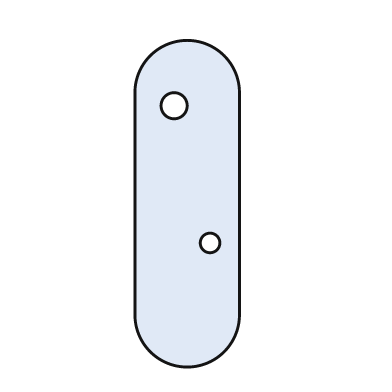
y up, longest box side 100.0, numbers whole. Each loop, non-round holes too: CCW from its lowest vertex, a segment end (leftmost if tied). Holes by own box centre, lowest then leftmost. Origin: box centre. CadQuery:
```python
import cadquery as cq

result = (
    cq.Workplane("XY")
    .moveTo(-16.0, -34.0)
    .threePointArc((0.0, -50.0), (16.0, -34.0))
    .lineTo(16.0, 34.0)
    .threePointArc((0.0, 50.0), (-16.0, 34.0))
    .close()
    .moveTo(7.0, -12.0)
    .circle(3.0)
    .moveTo(-4.0, 30.0)
    .circle(4.0)
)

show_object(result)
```